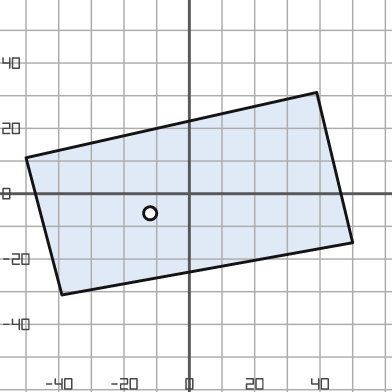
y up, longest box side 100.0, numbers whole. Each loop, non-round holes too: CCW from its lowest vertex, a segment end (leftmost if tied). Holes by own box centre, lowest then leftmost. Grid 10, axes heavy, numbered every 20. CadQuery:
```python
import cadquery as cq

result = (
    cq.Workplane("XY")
    .moveTo(-39.0, -31.0)
    .lineTo(50.0, -15.0)
    .lineTo(39.0, 31.0)
    .lineTo(-50.0, 11.0)
    .close()
    .moveTo(-12.0, -6.0)
    .circle(2.0)
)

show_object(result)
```